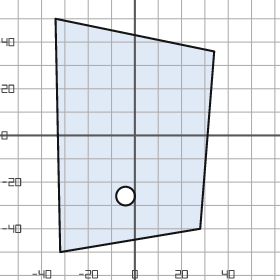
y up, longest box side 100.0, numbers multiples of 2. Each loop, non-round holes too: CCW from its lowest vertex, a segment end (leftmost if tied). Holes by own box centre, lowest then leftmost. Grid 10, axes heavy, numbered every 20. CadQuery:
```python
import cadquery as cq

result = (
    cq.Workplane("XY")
    .moveTo(-32.0, -50.0)
    .lineTo(28.0, -40.0)
    .lineTo(34.0, 36.0)
    .lineTo(-34.0, 50.0)
    .close()
    .moveTo(-4.0, -26.0)
    .circle(4.0)
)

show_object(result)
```